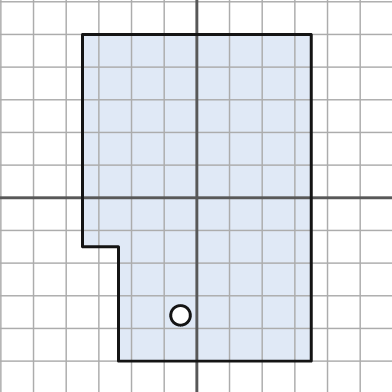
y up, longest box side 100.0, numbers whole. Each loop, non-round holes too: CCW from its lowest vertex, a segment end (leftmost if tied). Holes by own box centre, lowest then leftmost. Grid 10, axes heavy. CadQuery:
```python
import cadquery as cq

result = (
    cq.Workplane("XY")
    .moveTo(-24.0, -50.0)
    .lineTo(35.0, -50.0)
    .lineTo(35.0, 50.0)
    .lineTo(-35.0, 50.0)
    .lineTo(-35.0, -15.0)
    .lineTo(-24.0, -15.0)
    .close()
    .moveTo(-5.0, -36.0)
    .circle(3.0)
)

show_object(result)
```